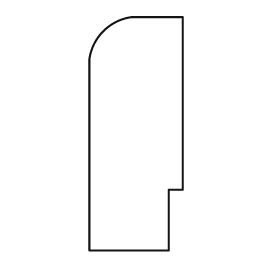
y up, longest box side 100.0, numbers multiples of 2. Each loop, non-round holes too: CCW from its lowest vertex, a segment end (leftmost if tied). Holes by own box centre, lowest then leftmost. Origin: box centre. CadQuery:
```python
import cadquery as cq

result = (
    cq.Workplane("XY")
    .moveTo(-20.0, -50.0)
    .lineTo(14.0, -50.0)
    .lineTo(14.0, -24.0)
    .lineTo(20.0, -24.0)
    .lineTo(20.0, 50.0)
    .lineTo(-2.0, 50.0)
    .threePointArc((-14.0, 44.0), (-20.0, 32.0))
    .close()
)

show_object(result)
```